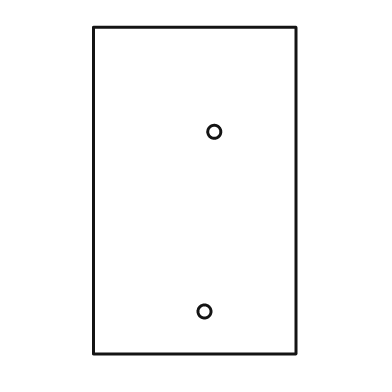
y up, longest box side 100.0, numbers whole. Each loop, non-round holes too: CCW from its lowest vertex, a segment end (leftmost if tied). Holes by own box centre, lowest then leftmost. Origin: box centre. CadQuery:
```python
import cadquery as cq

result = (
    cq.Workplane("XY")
    .moveTo(-31.0, -50.0)
    .lineTo(31.0, -50.0)
    .lineTo(31.0, 50.0)
    .lineTo(-31.0, 50.0)
    .close()
    .moveTo(3.0, -37.0)
    .circle(2.0)
    .moveTo(6.0, 18.0)
    .circle(2.0)
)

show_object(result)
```